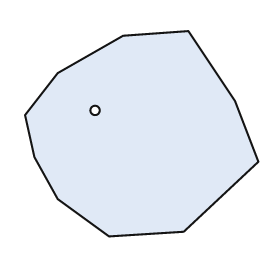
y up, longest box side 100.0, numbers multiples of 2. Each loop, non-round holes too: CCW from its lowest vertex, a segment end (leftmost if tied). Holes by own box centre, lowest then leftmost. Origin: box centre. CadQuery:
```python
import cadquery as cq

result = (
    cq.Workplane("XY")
    .moveTo(-14.0, -44.0)
    .lineTo(18.0, -42.0)
    .lineTo(50.0, -12.0)
    .lineTo(40.0, 14.0)
    .lineTo(20.0, 44.0)
    .lineTo(-8.0, 42.0)
    .lineTo(-36.0, 26.0)
    .lineTo(-50.0, 8.0)
    .lineTo(-46.0, -10.0)
    .lineTo(-36.0, -28.0)
    .close()
    .moveTo(-20.0, 10.0)
    .circle(2.0)
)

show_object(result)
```